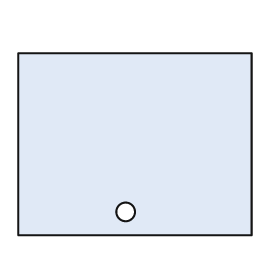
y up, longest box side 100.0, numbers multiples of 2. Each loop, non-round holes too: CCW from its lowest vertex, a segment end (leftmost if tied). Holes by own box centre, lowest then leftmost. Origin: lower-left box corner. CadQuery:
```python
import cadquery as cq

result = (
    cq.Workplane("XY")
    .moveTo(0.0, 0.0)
    .lineTo(100.0, 0.0)
    .lineTo(100.0, 78.0)
    .lineTo(0.0, 78.0)
    .close()
    .moveTo(46.0, 10.0)
    .circle(4.0)
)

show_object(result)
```